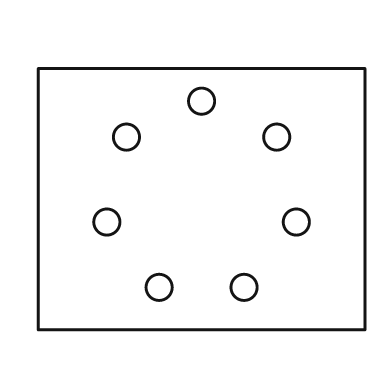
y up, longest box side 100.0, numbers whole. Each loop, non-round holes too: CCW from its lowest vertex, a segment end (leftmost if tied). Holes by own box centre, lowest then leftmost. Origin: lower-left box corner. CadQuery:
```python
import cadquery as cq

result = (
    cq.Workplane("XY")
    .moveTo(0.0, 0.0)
    .lineTo(100.0, 0.0)
    .lineTo(100.0, 80.0)
    .lineTo(0.0, 80.0)
    .close()
    .moveTo(37.0, 13.0)
    .circle(4.0)
    .moveTo(63.0, 13.0)
    .circle(4.0)
    .moveTo(21.0, 33.0)
    .circle(4.0)
    .moveTo(79.0, 33.0)
    .circle(4.0)
    .moveTo(27.0, 59.0)
    .circle(4.0)
    .moveTo(73.0, 59.0)
    .circle(4.0)
    .moveTo(50.0, 70.0)
    .circle(4.0)
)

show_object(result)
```